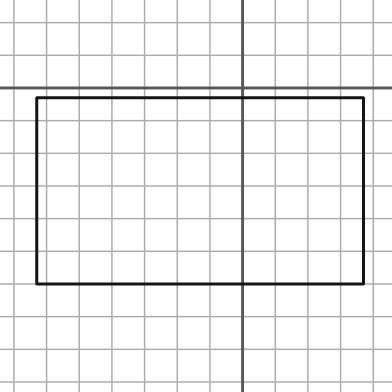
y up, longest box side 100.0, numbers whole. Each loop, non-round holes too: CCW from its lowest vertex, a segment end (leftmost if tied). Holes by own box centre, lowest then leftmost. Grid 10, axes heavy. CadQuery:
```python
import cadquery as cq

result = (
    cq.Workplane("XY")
    .moveTo(-63.0, -60.0)
    .lineTo(37.0, -60.0)
    .lineTo(37.0, -3.0)
    .lineTo(-63.0, -3.0)
    .close()
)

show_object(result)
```